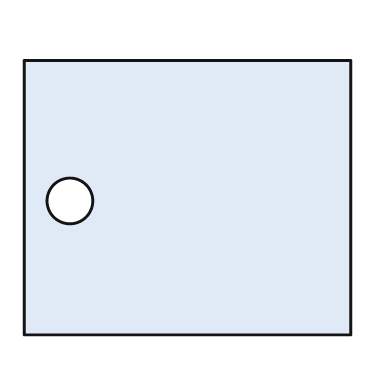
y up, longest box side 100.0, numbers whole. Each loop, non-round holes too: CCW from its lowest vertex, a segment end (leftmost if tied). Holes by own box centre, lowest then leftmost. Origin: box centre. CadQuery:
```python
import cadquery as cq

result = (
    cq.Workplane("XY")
    .moveTo(-50.0, -42.0)
    .lineTo(50.0, -42.0)
    .lineTo(50.0, 42.0)
    .lineTo(-50.0, 42.0)
    .close()
    .moveTo(-36.0, -1.0)
    .circle(7.0)
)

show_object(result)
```